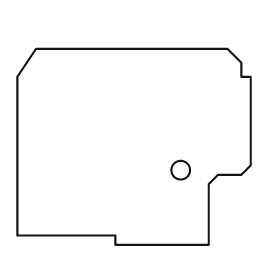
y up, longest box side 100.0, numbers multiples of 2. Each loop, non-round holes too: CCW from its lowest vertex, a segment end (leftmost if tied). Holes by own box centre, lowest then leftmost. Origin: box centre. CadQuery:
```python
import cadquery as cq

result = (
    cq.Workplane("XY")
    .moveTo(-8.0, -42.0)
    .lineTo(32.0, -42.0)
    .lineTo(32.0, -16.0)
    .lineTo(36.0, -12.0)
    .lineTo(46.0, -12.0)
    .lineTo(50.0, -8.0)
    .lineTo(50.0, 30.0)
    .lineTo(46.0, 30.0)
    .lineTo(46.0, 36.0)
    .lineTo(40.0, 42.0)
    .lineTo(-42.0, 42.0)
    .lineTo(-50.0, 30.0)
    .lineTo(-50.0, -38.0)
    .lineTo(-8.0, -38.0)
    .close()
    .moveTo(20.0, -10.0)
    .circle(4.0)
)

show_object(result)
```